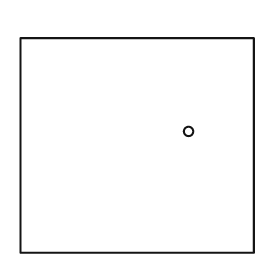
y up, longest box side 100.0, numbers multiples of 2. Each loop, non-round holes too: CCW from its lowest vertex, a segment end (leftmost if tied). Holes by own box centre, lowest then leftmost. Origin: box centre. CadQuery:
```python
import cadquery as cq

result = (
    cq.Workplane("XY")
    .moveTo(-50.0, -46.0)
    .lineTo(50.0, -46.0)
    .lineTo(50.0, 46.0)
    .lineTo(-50.0, 46.0)
    .close()
    .moveTo(22.0, 6.0)
    .circle(2.0)
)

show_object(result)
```